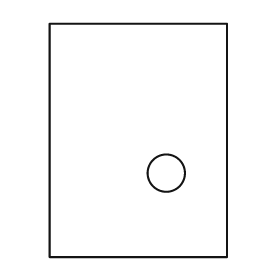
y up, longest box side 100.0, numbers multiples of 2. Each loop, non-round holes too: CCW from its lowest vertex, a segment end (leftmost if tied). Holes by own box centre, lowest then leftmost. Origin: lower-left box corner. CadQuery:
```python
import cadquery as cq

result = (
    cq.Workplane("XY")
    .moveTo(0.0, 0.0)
    .lineTo(76.0, 0.0)
    .lineTo(76.0, 100.0)
    .lineTo(0.0, 100.0)
    .close()
    .moveTo(50.0, 36.0)
    .circle(8.0)
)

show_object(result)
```